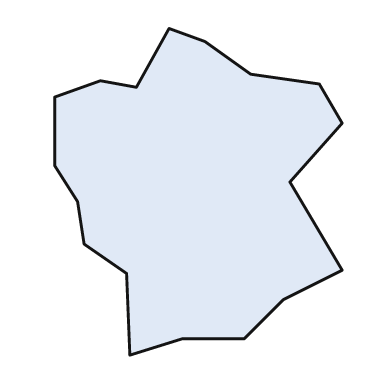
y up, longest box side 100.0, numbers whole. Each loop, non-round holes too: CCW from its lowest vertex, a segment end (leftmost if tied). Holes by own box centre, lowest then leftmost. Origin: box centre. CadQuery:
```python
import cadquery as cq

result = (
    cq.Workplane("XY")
    .moveTo(-21.0, -50.0)
    .lineTo(-5.0, -45.0)
    .lineTo(14.0, -45.0)
    .lineTo(26.0, -33.0)
    .lineTo(44.0, -24.0)
    .lineTo(28.0, 3.0)
    .lineTo(44.0, 21.0)
    .lineTo(37.0, 33.0)
    .lineTo(16.0, 36.0)
    .lineTo(2.0, 46.0)
    .lineTo(-9.0, 50.0)
    .lineTo(-19.0, 32.0)
    .lineTo(-30.0, 34.0)
    .lineTo(-44.0, 29.0)
    .lineTo(-44.0, 8.0)
    .lineTo(-37.0, -3.0)
    .lineTo(-35.0, -16.0)
    .lineTo(-22.0, -25.0)
    .close()
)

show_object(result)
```